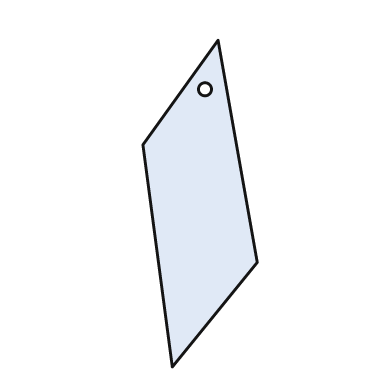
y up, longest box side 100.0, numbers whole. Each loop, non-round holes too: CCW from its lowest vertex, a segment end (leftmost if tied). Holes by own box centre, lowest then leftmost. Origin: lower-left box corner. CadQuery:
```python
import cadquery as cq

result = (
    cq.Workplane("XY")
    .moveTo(9.0, 0.0)
    .lineTo(35.0, 32.0)
    .lineTo(23.0, 100.0)
    .lineTo(0.0, 68.0)
    .close()
    .moveTo(19.0, 85.0)
    .circle(2.0)
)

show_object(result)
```